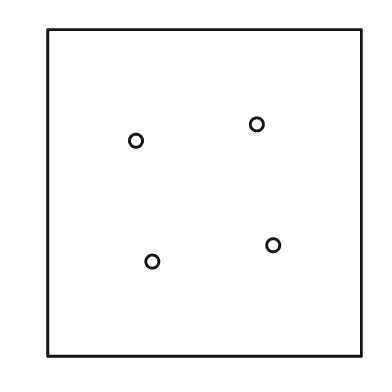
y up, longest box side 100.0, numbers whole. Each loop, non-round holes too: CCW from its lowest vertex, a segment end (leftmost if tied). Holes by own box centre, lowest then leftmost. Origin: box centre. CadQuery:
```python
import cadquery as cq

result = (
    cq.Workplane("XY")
    .moveTo(-48.0, -50.0)
    .lineTo(48.0, -50.0)
    .lineTo(48.0, 50.0)
    .lineTo(-48.0, 50.0)
    .close()
    .moveTo(-16.0, -21.0)
    .circle(2.0)
    .moveTo(21.0, -16.0)
    .circle(2.0)
    .moveTo(-21.0, 16.0)
    .circle(2.0)
    .moveTo(16.0, 21.0)
    .circle(2.0)
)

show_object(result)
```